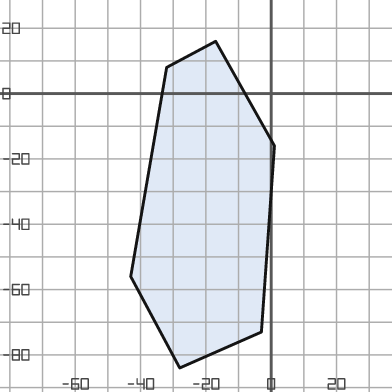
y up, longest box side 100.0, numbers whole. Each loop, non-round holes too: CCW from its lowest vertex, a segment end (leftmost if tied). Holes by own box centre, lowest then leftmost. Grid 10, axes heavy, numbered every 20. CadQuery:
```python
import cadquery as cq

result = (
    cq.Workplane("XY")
    .moveTo(-28.0, -84.0)
    .lineTo(-3.0, -73.0)
    .lineTo(1.0, -16.0)
    .lineTo(-17.0, 16.0)
    .lineTo(-32.0, 8.0)
    .lineTo(-43.0, -56.0)
    .close()
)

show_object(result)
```